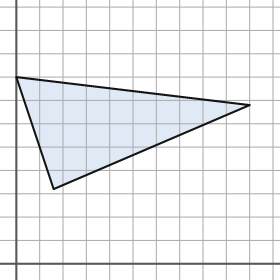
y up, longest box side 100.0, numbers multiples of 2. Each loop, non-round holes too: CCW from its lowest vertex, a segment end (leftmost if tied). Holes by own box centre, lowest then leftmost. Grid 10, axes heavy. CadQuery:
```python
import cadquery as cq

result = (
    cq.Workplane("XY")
    .moveTo(16.0, 32.0)
    .lineTo(100.0, 68.0)
    .lineTo(0.0, 80.0)
    .close()
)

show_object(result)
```